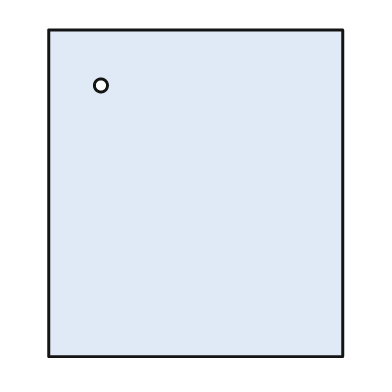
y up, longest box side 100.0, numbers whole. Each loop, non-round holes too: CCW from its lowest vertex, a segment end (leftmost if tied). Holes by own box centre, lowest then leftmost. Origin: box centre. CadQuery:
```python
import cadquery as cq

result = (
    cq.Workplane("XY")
    .moveTo(-45.0, -50.0)
    .lineTo(45.0, -50.0)
    .lineTo(45.0, 50.0)
    .lineTo(-45.0, 50.0)
    .close()
    .moveTo(-29.0, 33.0)
    .circle(2.0)
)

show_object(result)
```